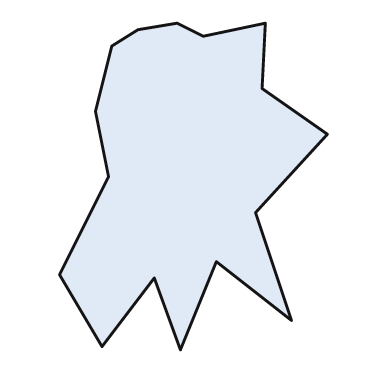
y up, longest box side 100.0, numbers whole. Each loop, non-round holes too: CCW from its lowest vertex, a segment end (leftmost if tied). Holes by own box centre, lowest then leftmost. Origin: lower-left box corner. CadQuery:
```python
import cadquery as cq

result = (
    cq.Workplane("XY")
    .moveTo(37.0, 0.0)
    .lineTo(48.0, 27.0)
    .lineTo(71.0, 9.0)
    .lineTo(60.0, 42.0)
    .lineTo(82.0, 66.0)
    .lineTo(62.0, 80.0)
    .lineTo(63.0, 100.0)
    .lineTo(44.0, 96.0)
    .lineTo(36.0, 100.0)
    .lineTo(24.0, 98.0)
    .lineTo(16.0, 93.0)
    .lineTo(11.0, 73.0)
    .lineTo(15.0, 53.0)
    .lineTo(0.0, 23.0)
    .lineTo(13.0, 1.0)
    .lineTo(29.0, 22.0)
    .close()
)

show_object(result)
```